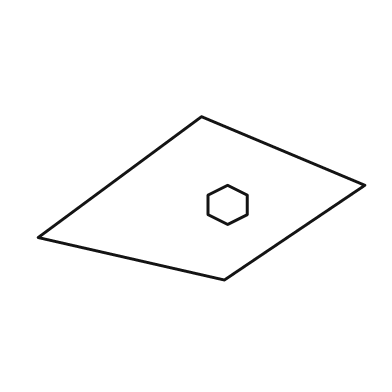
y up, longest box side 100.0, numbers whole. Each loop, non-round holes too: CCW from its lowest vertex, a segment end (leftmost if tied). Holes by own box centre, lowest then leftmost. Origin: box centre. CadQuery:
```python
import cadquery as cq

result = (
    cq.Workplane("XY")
    .moveTo(7.0, -25.0)
    .lineTo(50.0, 4.0)
    .lineTo(0.0, 25.0)
    .lineTo(-50.0, -12.0)
    .close()
    .moveTo(8.0, -8.0)
    .lineTo(14.0, -5.0)
    .lineTo(14.0, 1.0)
    .lineTo(8.0, 4.0)
    .lineTo(2.0, 1.0)
    .lineTo(2.0, -5.0)
    .close()
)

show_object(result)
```